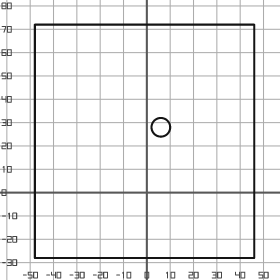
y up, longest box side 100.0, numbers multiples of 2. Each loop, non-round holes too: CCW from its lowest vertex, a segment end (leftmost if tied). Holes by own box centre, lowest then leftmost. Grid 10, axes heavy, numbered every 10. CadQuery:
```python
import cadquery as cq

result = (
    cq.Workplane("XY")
    .moveTo(-48.0, -28.0)
    .lineTo(46.0, -28.0)
    .lineTo(46.0, 72.0)
    .lineTo(-48.0, 72.0)
    .close()
    .moveTo(6.0, 28.0)
    .circle(4.0)
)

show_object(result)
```